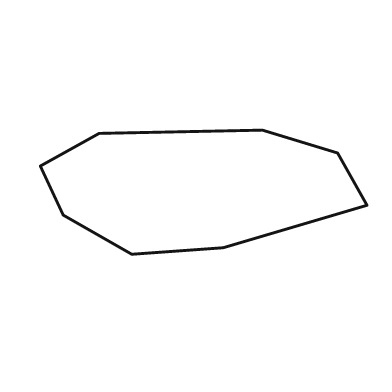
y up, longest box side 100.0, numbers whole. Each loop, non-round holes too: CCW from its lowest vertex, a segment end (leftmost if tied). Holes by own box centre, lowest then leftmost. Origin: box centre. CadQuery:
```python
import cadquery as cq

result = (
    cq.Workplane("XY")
    .moveTo(-22.0, -19.0)
    .lineTo(6.0, -17.0)
    .lineTo(50.0, -4.0)
    .lineTo(41.0, 12.0)
    .lineTo(18.0, 19.0)
    .lineTo(-32.0, 18.0)
    .lineTo(-50.0, 8.0)
    .lineTo(-43.0, -7.0)
    .close()
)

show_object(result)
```